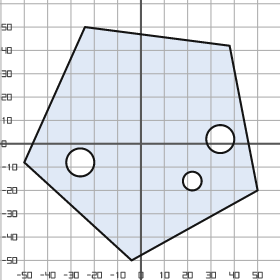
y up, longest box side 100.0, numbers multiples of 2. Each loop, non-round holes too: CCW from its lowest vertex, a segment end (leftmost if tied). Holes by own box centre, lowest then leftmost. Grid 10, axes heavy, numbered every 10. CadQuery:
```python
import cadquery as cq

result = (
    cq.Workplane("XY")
    .moveTo(-4.0, -50.0)
    .lineTo(50.0, -20.0)
    .lineTo(38.0, 42.0)
    .lineTo(-24.0, 50.0)
    .lineTo(-50.0, -8.0)
    .close()
    .moveTo(22.0, -16.0)
    .circle(4.0)
    .moveTo(-26.0, -8.0)
    .circle(6.0)
    .moveTo(34.0, 2.0)
    .circle(6.0)
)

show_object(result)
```